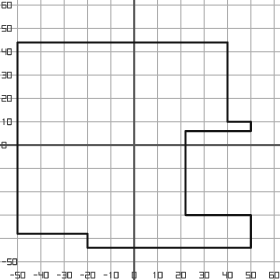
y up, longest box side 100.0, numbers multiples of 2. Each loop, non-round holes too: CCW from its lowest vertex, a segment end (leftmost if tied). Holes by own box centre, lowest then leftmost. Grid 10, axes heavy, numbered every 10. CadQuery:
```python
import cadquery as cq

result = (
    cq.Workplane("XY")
    .moveTo(-20.0, -44.0)
    .lineTo(50.0, -44.0)
    .lineTo(50.0, -30.0)
    .lineTo(22.0, -30.0)
    .lineTo(22.0, 6.0)
    .lineTo(50.0, 6.0)
    .lineTo(50.0, 10.0)
    .lineTo(40.0, 10.0)
    .lineTo(40.0, 44.0)
    .lineTo(-50.0, 44.0)
    .lineTo(-50.0, -38.0)
    .lineTo(-20.0, -38.0)
    .close()
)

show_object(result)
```